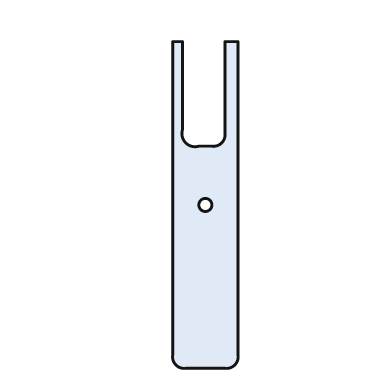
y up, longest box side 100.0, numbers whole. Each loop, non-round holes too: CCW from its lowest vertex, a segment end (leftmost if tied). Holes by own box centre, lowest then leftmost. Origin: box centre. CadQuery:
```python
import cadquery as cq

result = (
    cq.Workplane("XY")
    .moveTo(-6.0, -50.0)
    .lineTo(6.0, -50.0)
    .threePointArc((9.0, -49.0), (10.0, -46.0))
    .lineTo(10.0, 50.0)
    .lineTo(6.0, 50.0)
    .lineTo(6.0, 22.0)
    .threePointArc((5.0, 19.0), (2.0, 18.0))
    .lineTo(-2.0, 18.0)
    .threePointArc((-6.0, 19.0), (-7.0, 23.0))
    .lineTo(-7.0, 50.0)
    .lineTo(-10.0, 50.0)
    .lineTo(-10.0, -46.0)
    .threePointArc((-9.0, -49.0), (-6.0, -50.0))
    .close()
    .moveTo(0.0, 0.0)
    .circle(2.0)
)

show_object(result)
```